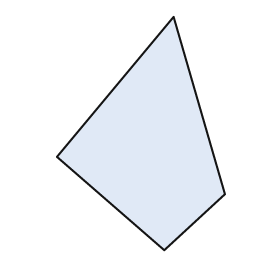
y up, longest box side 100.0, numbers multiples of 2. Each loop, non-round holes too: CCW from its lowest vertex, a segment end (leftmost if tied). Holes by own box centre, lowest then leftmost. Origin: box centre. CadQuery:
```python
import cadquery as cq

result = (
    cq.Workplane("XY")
    .moveTo(10.0, -50.0)
    .lineTo(36.0, -26.0)
    .lineTo(14.0, 50.0)
    .lineTo(-36.0, -10.0)
    .close()
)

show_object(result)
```